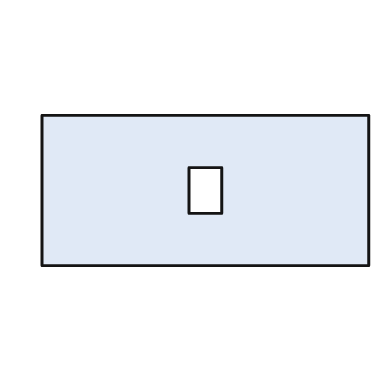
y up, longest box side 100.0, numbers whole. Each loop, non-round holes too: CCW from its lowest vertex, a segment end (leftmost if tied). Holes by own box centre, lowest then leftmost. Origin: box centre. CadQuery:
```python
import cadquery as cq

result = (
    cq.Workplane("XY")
    .moveTo(-50.0, -23.0)
    .lineTo(50.0, -23.0)
    .lineTo(50.0, 23.0)
    .lineTo(-50.0, 23.0)
    .close()
    .moveTo(-5.0, -7.0)
    .lineTo(5.0, -7.0)
    .lineTo(5.0, 7.0)
    .lineTo(-5.0, 7.0)
    .close()
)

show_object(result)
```